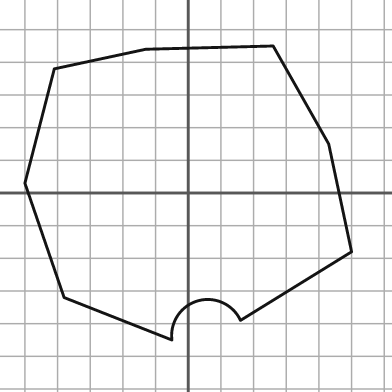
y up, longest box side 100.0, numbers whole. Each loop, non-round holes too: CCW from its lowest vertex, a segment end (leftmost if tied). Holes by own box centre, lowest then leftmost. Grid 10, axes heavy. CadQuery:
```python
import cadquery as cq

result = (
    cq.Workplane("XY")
    .moveTo(-5.0, -45.0)
    .threePointArc((3.0, -33.0), (16.0, -39.0))
    .lineTo(50.0, -18.0)
    .lineTo(43.0, 15.0)
    .lineTo(26.0, 45.0)
    .lineTo(-13.0, 44.0)
    .lineTo(-41.0, 38.0)
    .lineTo(-50.0, 3.0)
    .lineTo(-38.0, -32.0)
    .close()
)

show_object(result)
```